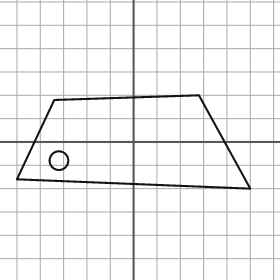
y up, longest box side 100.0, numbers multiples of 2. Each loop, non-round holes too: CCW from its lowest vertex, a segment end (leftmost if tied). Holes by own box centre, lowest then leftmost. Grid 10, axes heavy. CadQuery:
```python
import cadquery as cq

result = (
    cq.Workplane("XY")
    .moveTo(50.0, -20.0)
    .lineTo(28.0, 20.0)
    .lineTo(-34.0, 18.0)
    .lineTo(-50.0, -16.0)
    .close()
    .moveTo(-32.0, -8.0)
    .circle(4.0)
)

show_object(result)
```